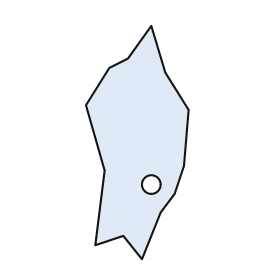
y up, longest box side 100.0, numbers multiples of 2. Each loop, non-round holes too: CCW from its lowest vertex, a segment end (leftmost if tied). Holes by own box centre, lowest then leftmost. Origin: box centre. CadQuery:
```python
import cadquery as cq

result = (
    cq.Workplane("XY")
    .moveTo(2.0, -50.0)
    .lineTo(10.0, -30.0)
    .lineTo(16.0, -22.0)
    .lineTo(20.0, -10.0)
    .lineTo(22.0, 14.0)
    .lineTo(12.0, 30.0)
    .lineTo(6.0, 50.0)
    .lineTo(-4.0, 36.0)
    .lineTo(-12.0, 32.0)
    .lineTo(-22.0, 16.0)
    .lineTo(-14.0, -12.0)
    .lineTo(-18.0, -44.0)
    .lineTo(-6.0, -40.0)
    .close()
    .moveTo(6.0, -18.0)
    .circle(4.0)
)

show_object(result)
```